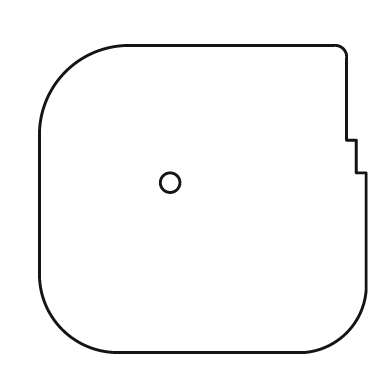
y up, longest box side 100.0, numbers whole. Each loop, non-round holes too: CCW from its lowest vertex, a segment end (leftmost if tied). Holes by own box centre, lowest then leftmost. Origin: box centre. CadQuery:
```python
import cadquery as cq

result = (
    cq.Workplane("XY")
    .moveTo(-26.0, -47.0)
    .lineTo(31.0, -47.0)
    .threePointArc((44.0, -41.0), (50.0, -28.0))
    .lineTo(50.0, 8.0)
    .lineTo(47.0, 8.0)
    .lineTo(47.0, 18.0)
    .lineTo(44.0, 18.0)
    .lineTo(44.0, 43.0)
    .threePointArc((43.0, 46.0), (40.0, 47.0))
    .lineTo(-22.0, 47.0)
    .threePointArc((-42.0, 39.0), (-50.0, 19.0))
    .lineTo(-50.0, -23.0)
    .threePointArc((-43.0, -40.0), (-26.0, -47.0))
    .close()
    .moveTo(-10.0, 5.0)
    .circle(3.0)
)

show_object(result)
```